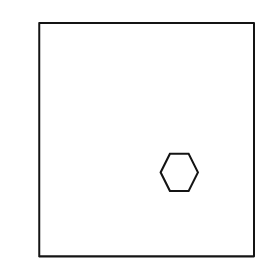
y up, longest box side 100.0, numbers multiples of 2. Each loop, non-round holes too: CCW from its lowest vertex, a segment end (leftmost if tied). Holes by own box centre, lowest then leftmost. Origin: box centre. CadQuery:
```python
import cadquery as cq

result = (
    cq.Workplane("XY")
    .moveTo(-46.0, -50.0)
    .lineTo(46.0, -50.0)
    .lineTo(46.0, 50.0)
    .lineTo(-46.0, 50.0)
    .close()
    .moveTo(10.0, -22.0)
    .lineTo(18.0, -22.0)
    .lineTo(22.0, -14.0)
    .lineTo(18.0, -6.0)
    .lineTo(10.0, -6.0)
    .lineTo(6.0, -14.0)
    .close()
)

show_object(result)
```